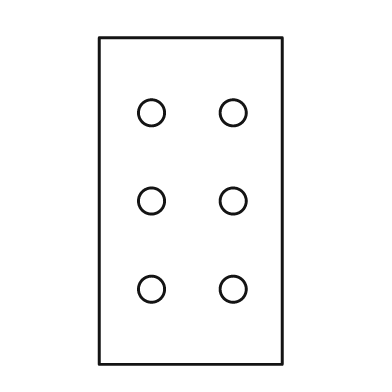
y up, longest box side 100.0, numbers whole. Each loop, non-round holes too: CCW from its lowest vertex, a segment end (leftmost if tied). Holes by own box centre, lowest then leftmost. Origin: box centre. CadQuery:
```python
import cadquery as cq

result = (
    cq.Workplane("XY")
    .moveTo(-28.0, -50.0)
    .lineTo(28.0, -50.0)
    .lineTo(28.0, 50.0)
    .lineTo(-28.0, 50.0)
    .close()
    .moveTo(-12.0, -27.0)
    .circle(4.0)
    .moveTo(13.0, -27.0)
    .circle(4.0)
    .moveTo(-12.0, 0.0)
    .circle(4.0)
    .moveTo(13.0, 0.0)
    .circle(4.0)
    .moveTo(-12.0, 27.0)
    .circle(4.0)
    .moveTo(13.0, 27.0)
    .circle(4.0)
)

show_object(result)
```